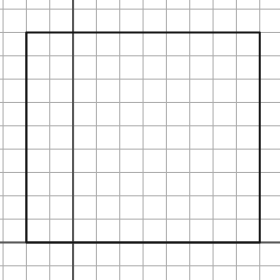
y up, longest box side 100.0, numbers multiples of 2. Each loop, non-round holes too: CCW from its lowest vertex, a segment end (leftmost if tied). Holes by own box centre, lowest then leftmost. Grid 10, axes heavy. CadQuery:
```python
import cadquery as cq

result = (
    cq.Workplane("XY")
    .moveTo(-20.0, 0.0)
    .lineTo(80.0, 0.0)
    .lineTo(80.0, 90.0)
    .lineTo(-20.0, 90.0)
    .close()
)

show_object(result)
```